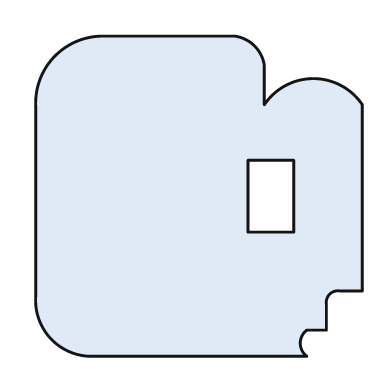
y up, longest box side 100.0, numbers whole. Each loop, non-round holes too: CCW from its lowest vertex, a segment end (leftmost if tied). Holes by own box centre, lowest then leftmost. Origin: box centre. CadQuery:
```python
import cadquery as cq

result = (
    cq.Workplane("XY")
    .moveTo(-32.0, -49.0)
    .lineTo(33.0, -49.0)
    .threePointArc((31.0, -45.0), (33.0, -41.0))
    .lineTo(39.0, -41.0)
    .lineTo(39.0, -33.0)
    .threePointArc((40.0, -30.0), (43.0, -29.0))
    .lineTo(50.0, -29.0)
    .lineTo(50.0, 28.0)
    .threePointArc((35.0, 36.0), (20.0, 28.0))
    .lineTo(20.0, 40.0)
    .threePointArc((17.0, 46.0), (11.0, 49.0))
    .lineTo(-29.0, 49.0)
    .threePointArc((-44.0, 43.0), (-50.0, 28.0))
    .lineTo(-50.0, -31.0)
    .threePointArc((-45.0, -44.0), (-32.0, -49.0))
    .close()
    .moveTo(15.0, -11.0)
    .lineTo(29.0, -11.0)
    .lineTo(29.0, 11.0)
    .lineTo(15.0, 11.0)
    .close()
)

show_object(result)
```